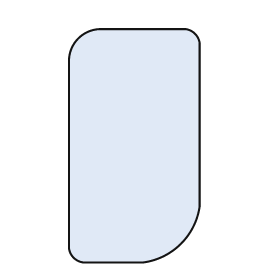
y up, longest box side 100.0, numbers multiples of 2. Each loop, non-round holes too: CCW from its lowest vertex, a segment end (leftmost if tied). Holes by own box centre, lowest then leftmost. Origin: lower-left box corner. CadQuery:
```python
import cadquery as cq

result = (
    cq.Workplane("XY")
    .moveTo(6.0, 0.0)
    .lineTo(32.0, 0.0)
    .threePointArc((48.0, 8.0), (56.0, 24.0))
    .lineTo(56.0, 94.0)
    .threePointArc((54.0, 98.0), (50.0, 100.0))
    .lineTo(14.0, 100.0)
    .threePointArc((4.0, 96.0), (0.0, 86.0))
    .lineTo(0.0, 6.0)
    .threePointArc((2.0, 2.0), (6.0, 0.0))
    .close()
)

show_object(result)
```